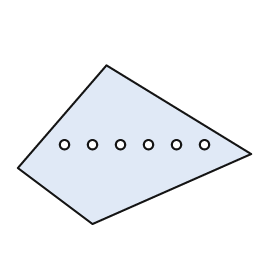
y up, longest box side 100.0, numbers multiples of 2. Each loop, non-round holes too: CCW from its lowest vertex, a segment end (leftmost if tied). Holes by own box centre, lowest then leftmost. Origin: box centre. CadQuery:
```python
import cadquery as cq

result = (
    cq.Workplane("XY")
    .moveTo(-18.0, -34.0)
    .lineTo(50.0, -4.0)
    .lineTo(-12.0, 34.0)
    .lineTo(-50.0, -10.0)
    .close()
    .moveTo(-30.0, 0.0)
    .circle(2.0)
    .moveTo(-18.0, 0.0)
    .circle(2.0)
    .moveTo(-6.0, 0.0)
    .circle(2.0)
    .moveTo(6.0, 0.0)
    .circle(2.0)
    .moveTo(18.0, 0.0)
    .circle(2.0)
    .moveTo(30.0, 0.0)
    .circle(2.0)
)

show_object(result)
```